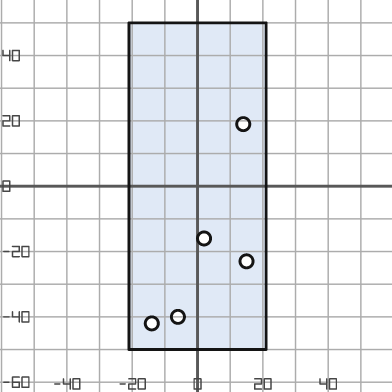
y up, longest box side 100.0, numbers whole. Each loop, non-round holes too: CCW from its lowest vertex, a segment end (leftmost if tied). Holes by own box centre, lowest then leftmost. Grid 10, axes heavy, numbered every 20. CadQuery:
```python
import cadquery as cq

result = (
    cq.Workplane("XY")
    .moveTo(-21.0, -50.0)
    .lineTo(21.0, -50.0)
    .lineTo(21.0, 50.0)
    .lineTo(-21.0, 50.0)
    .close()
    .moveTo(-14.0, -42.0)
    .circle(2.0)
    .moveTo(-6.0, -40.0)
    .circle(2.0)
    .moveTo(15.0, -23.0)
    .circle(2.0)
    .moveTo(2.0, -16.0)
    .circle(2.0)
    .moveTo(14.0, 19.0)
    .circle(2.0)
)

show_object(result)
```